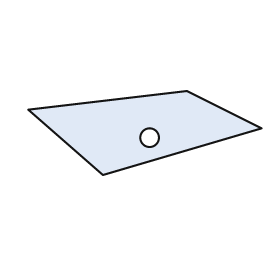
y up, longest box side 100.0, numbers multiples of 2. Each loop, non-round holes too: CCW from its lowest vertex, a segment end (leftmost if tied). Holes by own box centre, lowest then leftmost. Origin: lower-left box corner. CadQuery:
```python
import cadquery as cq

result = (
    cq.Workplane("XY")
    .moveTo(32.0, 0.0)
    .lineTo(100.0, 20.0)
    .lineTo(68.0, 36.0)
    .lineTo(0.0, 28.0)
    .close()
    .moveTo(52.0, 16.0)
    .circle(4.0)
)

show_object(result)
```